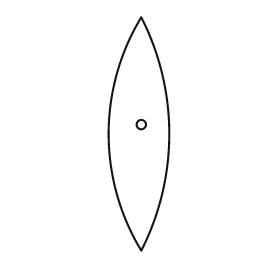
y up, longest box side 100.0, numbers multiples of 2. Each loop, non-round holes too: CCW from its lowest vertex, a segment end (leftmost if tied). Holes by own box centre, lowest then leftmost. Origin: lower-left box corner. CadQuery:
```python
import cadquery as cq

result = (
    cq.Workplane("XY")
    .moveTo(14.0, 0.0)
    .threePointArc((26.0, 50.0), (14.0, 100.0))
    .threePointArc((0.0, 50.0), (14.0, 0.0))
    .close()
    .moveTo(14.0, 54.0)
    .circle(2.0)
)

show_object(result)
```